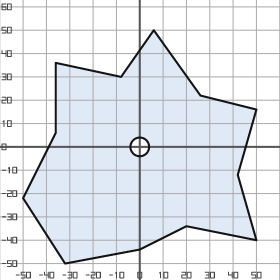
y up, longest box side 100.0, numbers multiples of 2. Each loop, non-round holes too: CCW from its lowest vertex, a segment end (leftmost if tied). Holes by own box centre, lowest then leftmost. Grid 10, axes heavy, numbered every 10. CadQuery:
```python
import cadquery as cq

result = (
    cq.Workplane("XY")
    .moveTo(-32.0, -50.0)
    .lineTo(0.0, -44.0)
    .lineTo(20.0, -34.0)
    .lineTo(50.0, -40.0)
    .lineTo(42.0, -12.0)
    .lineTo(50.0, 16.0)
    .lineTo(26.0, 22.0)
    .lineTo(6.0, 50.0)
    .lineTo(-8.0, 30.0)
    .lineTo(-36.0, 36.0)
    .lineTo(-36.0, 6.0)
    .lineTo(-50.0, -22.0)
    .close()
    .moveTo(0.0, 0.0)
    .circle(4.0)
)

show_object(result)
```